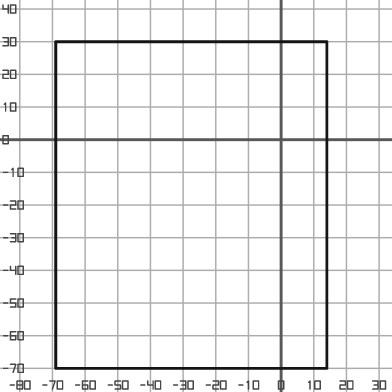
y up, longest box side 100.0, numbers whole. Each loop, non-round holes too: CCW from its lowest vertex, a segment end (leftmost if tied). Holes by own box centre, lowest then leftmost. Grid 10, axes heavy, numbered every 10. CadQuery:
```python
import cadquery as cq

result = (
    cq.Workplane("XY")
    .moveTo(-69.0, -70.0)
    .lineTo(14.0, -70.0)
    .lineTo(14.0, 30.0)
    .lineTo(-69.0, 30.0)
    .close()
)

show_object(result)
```